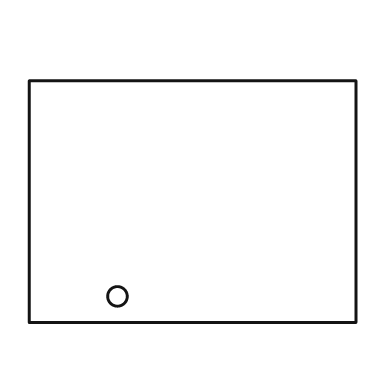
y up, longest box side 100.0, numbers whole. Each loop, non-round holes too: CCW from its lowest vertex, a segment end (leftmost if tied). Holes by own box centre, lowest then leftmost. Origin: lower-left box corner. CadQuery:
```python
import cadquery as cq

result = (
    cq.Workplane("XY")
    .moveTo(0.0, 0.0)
    .lineTo(100.0, 0.0)
    .lineTo(100.0, 74.0)
    .lineTo(0.0, 74.0)
    .close()
    .moveTo(27.0, 8.0)
    .circle(3.0)
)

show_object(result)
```